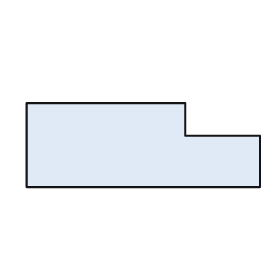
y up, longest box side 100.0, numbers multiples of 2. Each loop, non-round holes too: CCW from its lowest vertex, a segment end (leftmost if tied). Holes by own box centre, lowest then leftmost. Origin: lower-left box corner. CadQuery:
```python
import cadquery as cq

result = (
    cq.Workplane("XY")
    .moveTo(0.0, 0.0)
    .lineTo(100.0, 0.0)
    .lineTo(100.0, 22.0)
    .lineTo(68.0, 22.0)
    .lineTo(68.0, 36.0)
    .lineTo(0.0, 36.0)
    .close()
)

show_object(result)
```